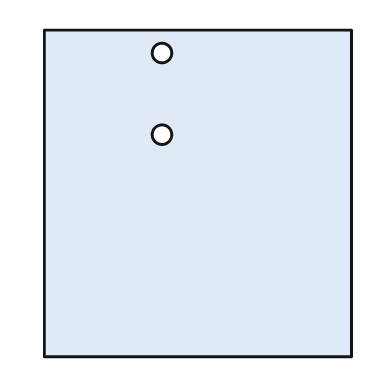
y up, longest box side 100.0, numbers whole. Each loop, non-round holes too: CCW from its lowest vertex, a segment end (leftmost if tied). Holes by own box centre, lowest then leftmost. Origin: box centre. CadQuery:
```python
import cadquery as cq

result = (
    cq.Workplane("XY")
    .moveTo(-47.0, -50.0)
    .lineTo(47.0, -50.0)
    .lineTo(47.0, 50.0)
    .lineTo(-47.0, 50.0)
    .close()
    .moveTo(-11.0, 18.0)
    .circle(3.0)
    .moveTo(-11.0, 43.0)
    .circle(3.0)
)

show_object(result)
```